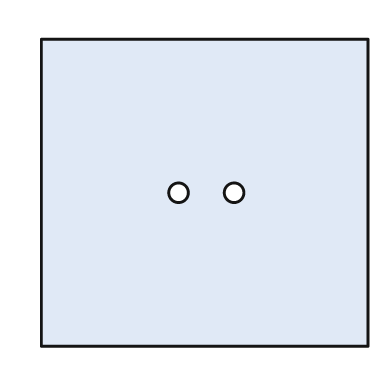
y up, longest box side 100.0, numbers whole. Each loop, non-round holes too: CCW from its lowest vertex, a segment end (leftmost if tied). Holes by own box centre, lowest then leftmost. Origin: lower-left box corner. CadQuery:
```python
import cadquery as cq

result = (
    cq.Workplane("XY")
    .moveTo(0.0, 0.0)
    .lineTo(100.0, 0.0)
    .lineTo(100.0, 94.0)
    .lineTo(0.0, 94.0)
    .close()
    .moveTo(42.0, 47.0)
    .circle(3.0)
    .moveTo(59.0, 47.0)
    .circle(3.0)
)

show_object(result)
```